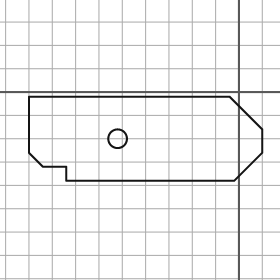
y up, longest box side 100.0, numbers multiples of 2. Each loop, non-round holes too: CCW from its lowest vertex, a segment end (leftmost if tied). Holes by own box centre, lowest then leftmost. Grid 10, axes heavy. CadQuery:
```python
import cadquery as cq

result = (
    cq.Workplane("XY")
    .moveTo(-74.0, -38.0)
    .lineTo(-2.0, -38.0)
    .lineTo(10.0, -26.0)
    .lineTo(10.0, -16.0)
    .lineTo(-4.0, -2.0)
    .lineTo(-90.0, -2.0)
    .lineTo(-90.0, -26.0)
    .lineTo(-84.0, -32.0)
    .lineTo(-74.0, -32.0)
    .close()
    .moveTo(-52.0, -20.0)
    .circle(4.0)
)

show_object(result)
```